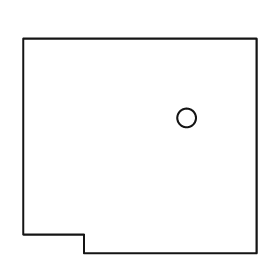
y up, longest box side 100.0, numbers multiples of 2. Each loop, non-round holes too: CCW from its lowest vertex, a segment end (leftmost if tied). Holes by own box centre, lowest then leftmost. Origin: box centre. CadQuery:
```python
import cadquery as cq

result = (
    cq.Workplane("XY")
    .moveTo(-24.0, -46.0)
    .lineTo(50.0, -46.0)
    .lineTo(50.0, 46.0)
    .lineTo(-50.0, 46.0)
    .lineTo(-50.0, -38.0)
    .lineTo(-24.0, -38.0)
    .close()
    .moveTo(20.0, 12.0)
    .circle(4.0)
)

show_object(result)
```